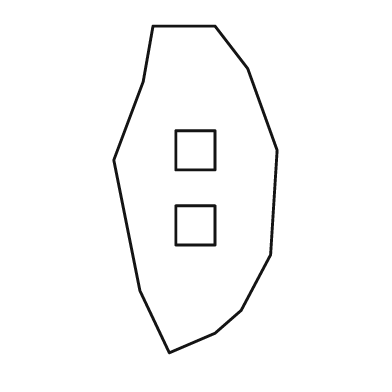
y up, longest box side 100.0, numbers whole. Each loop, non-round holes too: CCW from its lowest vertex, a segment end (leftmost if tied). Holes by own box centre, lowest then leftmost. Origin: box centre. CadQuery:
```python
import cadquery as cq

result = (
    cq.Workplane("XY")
    .moveTo(-8.0, -50.0)
    .lineTo(6.0, -44.0)
    .lineTo(14.0, -37.0)
    .lineTo(23.0, -20.0)
    .lineTo(25.0, 12.0)
    .lineTo(16.0, 37.0)
    .lineTo(6.0, 50.0)
    .lineTo(-13.0, 50.0)
    .lineTo(-16.0, 33.0)
    .lineTo(-25.0, 9.0)
    .lineTo(-17.0, -31.0)
    .close()
    .moveTo(-6.0, -17.0)
    .lineTo(6.0, -17.0)
    .lineTo(6.0, -5.0)
    .lineTo(-6.0, -5.0)
    .close()
    .moveTo(-6.0, 6.0)
    .lineTo(6.0, 6.0)
    .lineTo(6.0, 18.0)
    .lineTo(-6.0, 18.0)
    .close()
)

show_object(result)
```